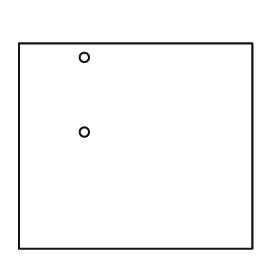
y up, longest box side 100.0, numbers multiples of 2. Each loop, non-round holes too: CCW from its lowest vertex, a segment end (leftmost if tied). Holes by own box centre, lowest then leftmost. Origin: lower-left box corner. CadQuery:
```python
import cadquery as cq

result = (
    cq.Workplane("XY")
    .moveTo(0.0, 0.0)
    .lineTo(100.0, 0.0)
    .lineTo(100.0, 88.0)
    .lineTo(0.0, 88.0)
    .close()
    .moveTo(28.0, 50.0)
    .circle(2.0)
    .moveTo(28.0, 82.0)
    .circle(2.0)
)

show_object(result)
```